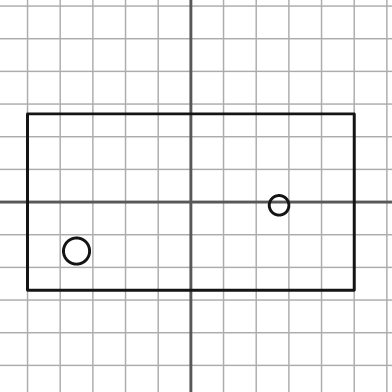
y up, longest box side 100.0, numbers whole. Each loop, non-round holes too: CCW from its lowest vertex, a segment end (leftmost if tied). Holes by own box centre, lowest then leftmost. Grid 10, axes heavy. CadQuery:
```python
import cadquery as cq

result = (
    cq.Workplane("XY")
    .moveTo(-50.0, -27.0)
    .lineTo(50.0, -27.0)
    .lineTo(50.0, 27.0)
    .lineTo(-50.0, 27.0)
    .close()
    .moveTo(-35.0, -15.0)
    .circle(4.0)
    .moveTo(27.0, -1.0)
    .circle(3.0)
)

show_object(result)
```